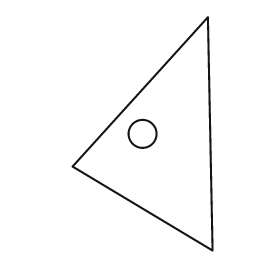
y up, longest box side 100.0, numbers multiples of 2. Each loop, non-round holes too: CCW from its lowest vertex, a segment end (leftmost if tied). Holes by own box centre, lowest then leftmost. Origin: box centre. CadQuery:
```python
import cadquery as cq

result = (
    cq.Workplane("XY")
    .moveTo(30.0, -50.0)
    .lineTo(28.0, 50.0)
    .lineTo(-30.0, -14.0)
    .close()
    .moveTo(0.0, 0.0)
    .circle(6.0)
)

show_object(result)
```